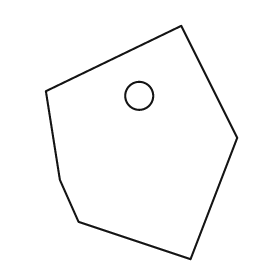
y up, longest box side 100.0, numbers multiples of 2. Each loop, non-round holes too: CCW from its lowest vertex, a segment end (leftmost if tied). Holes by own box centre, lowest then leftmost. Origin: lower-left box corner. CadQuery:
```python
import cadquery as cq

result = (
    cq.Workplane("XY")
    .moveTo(62.0, 0.0)
    .lineTo(82.0, 52.0)
    .lineTo(58.0, 100.0)
    .lineTo(0.0, 72.0)
    .lineTo(6.0, 34.0)
    .lineTo(14.0, 16.0)
    .close()
    .moveTo(40.0, 70.0)
    .circle(6.0)
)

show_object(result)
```